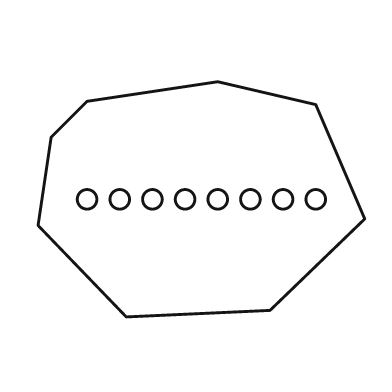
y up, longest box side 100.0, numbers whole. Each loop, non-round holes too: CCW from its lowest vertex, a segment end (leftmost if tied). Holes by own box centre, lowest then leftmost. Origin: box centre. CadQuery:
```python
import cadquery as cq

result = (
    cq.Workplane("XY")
    .moveTo(-23.0, -36.0)
    .lineTo(21.0, -34.0)
    .lineTo(50.0, -6.0)
    .lineTo(35.0, 29.0)
    .lineTo(5.0, 36.0)
    .lineTo(-35.0, 30.0)
    .lineTo(-46.0, 19.0)
    .lineTo(-50.0, -8.0)
    .close()
    .moveTo(-35.0, 0.0)
    .circle(3.0)
    .moveTo(-25.0, 0.0)
    .circle(3.0)
    .moveTo(-15.0, 0.0)
    .circle(3.0)
    .moveTo(-5.0, 0.0)
    .circle(3.0)
    .moveTo(5.0, 0.0)
    .circle(3.0)
    .moveTo(15.0, 0.0)
    .circle(3.0)
    .moveTo(25.0, 0.0)
    .circle(3.0)
    .moveTo(35.0, 0.0)
    .circle(3.0)
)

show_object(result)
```